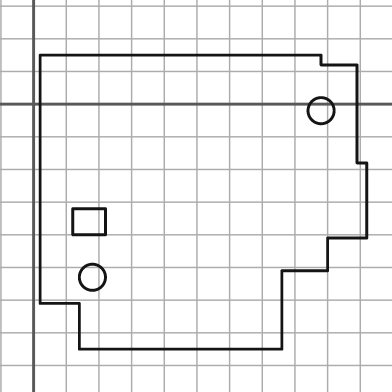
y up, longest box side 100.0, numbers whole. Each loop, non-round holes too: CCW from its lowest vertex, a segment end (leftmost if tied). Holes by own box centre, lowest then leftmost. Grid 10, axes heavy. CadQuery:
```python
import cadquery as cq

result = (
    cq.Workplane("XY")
    .moveTo(14.0, -75.0)
    .lineTo(76.0, -75.0)
    .lineTo(76.0, -51.0)
    .lineTo(90.0, -51.0)
    .lineTo(90.0, -41.0)
    .lineTo(102.0, -41.0)
    .lineTo(102.0, -18.0)
    .lineTo(99.0, -18.0)
    .lineTo(99.0, 12.0)
    .lineTo(88.0, 12.0)
    .lineTo(88.0, 15.0)
    .lineTo(2.0, 15.0)
    .lineTo(2.0, -61.0)
    .lineTo(14.0, -61.0)
    .close()
    .moveTo(18.0, -53.0)
    .circle(4.0)
    .moveTo(12.0, -40.0)
    .lineTo(22.0, -40.0)
    .lineTo(22.0, -32.0)
    .lineTo(12.0, -32.0)
    .close()
    .moveTo(88.0, -2.0)
    .circle(4.0)
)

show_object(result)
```